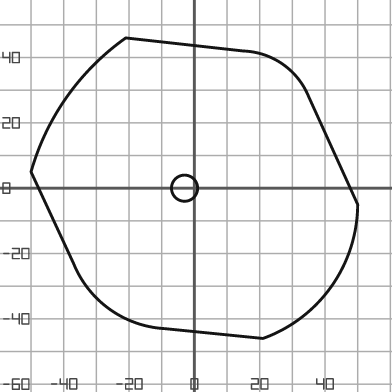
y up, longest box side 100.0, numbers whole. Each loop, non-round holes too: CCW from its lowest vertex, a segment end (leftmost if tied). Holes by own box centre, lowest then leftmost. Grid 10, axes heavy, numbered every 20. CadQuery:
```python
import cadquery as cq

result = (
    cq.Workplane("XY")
    .moveTo(21.0, -46.0)
    .threePointArc((42.0, -30.0), (50.0, -5.0))
    .lineTo(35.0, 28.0)
    .threePointArc((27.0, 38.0), (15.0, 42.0))
    .lineTo(-21.0, 46.0)
    .threePointArc((-39.0, 28.0), (-50.0, 5.0))
    .lineTo(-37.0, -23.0)
    .threePointArc((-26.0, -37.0), (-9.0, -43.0))
    .close()
    .moveTo(-3.0, 0.0)
    .circle(4.0)
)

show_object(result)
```